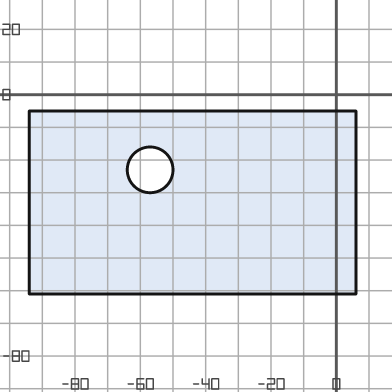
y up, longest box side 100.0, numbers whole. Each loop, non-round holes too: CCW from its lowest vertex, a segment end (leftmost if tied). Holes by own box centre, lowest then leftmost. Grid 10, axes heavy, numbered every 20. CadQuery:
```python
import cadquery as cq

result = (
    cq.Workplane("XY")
    .moveTo(-94.0, -61.0)
    .lineTo(6.0, -61.0)
    .lineTo(6.0, -5.0)
    .lineTo(-94.0, -5.0)
    .close()
    .moveTo(-57.0, -23.0)
    .circle(7.0)
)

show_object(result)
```